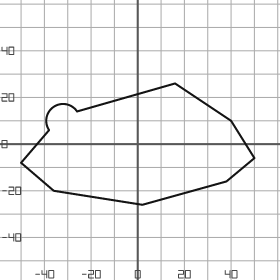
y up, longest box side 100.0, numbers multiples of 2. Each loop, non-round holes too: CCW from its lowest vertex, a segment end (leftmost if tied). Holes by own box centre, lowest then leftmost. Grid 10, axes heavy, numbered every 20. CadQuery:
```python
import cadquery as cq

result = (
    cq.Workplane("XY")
    .moveTo(2.0, -26.0)
    .lineTo(38.0, -16.0)
    .lineTo(50.0, -6.0)
    .lineTo(40.0, 10.0)
    .lineTo(16.0, 26.0)
    .lineTo(-26.0, 14.0)
    .threePointArc((-36.0, 16.0), (-38.0, 6.0))
    .lineTo(-50.0, -8.0)
    .lineTo(-36.0, -20.0)
    .close()
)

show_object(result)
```